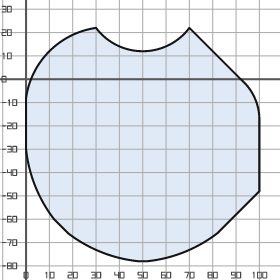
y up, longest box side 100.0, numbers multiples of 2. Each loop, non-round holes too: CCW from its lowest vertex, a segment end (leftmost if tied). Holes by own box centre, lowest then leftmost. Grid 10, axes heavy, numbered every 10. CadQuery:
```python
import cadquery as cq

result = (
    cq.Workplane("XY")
    .moveTo(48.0, -78.0)
    .lineTo(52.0, -78.0)
    .threePointArc((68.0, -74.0), (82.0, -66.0))
    .lineTo(100.0, -48.0)
    .lineTo(100.0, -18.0)
    .threePointArc((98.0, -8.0), (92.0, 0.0))
    .lineTo(70.0, 22.0)
    .threePointArc((50.0, 12.0), (30.0, 22.0))
    .threePointArc((10.0, 12.0), (0.0, -8.0))
    .lineTo(0.0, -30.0)
    .threePointArc((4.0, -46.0), (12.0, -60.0))
    .lineTo(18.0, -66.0)
    .threePointArc((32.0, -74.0), (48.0, -78.0))
    .close()
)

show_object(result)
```